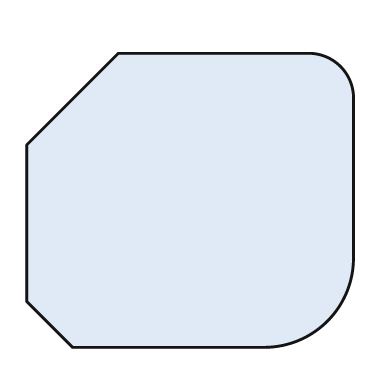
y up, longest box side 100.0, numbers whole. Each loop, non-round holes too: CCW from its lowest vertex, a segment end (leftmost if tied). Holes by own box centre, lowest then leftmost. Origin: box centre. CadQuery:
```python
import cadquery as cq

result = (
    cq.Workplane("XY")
    .moveTo(-36.0, -45.0)
    .lineTo(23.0, -45.0)
    .threePointArc((42.0, -37.0), (50.0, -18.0))
    .lineTo(50.0, 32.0)
    .threePointArc((46.0, 41.0), (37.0, 45.0))
    .lineTo(-22.0, 45.0)
    .lineTo(-50.0, 17.0)
    .lineTo(-50.0, -31.0)
    .close()
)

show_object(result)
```